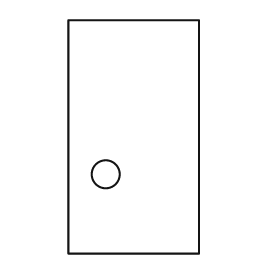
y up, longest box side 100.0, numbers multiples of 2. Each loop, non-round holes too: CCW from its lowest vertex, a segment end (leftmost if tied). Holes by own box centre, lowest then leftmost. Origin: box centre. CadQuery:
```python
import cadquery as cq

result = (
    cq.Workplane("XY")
    .moveTo(-28.0, -50.0)
    .lineTo(28.0, -50.0)
    .lineTo(28.0, 50.0)
    .lineTo(-28.0, 50.0)
    .close()
    .moveTo(-12.0, -16.0)
    .circle(6.0)
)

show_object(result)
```